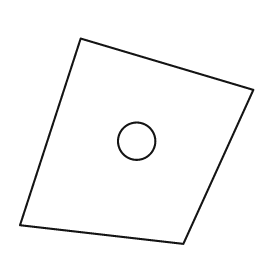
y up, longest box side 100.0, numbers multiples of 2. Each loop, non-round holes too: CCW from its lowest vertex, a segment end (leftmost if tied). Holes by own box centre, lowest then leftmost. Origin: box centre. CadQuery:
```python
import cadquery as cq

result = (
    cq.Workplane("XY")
    .moveTo(20.0, -44.0)
    .lineTo(50.0, 22.0)
    .lineTo(-24.0, 44.0)
    .lineTo(-50.0, -36.0)
    .close()
    .moveTo(0.0, 0.0)
    .circle(8.0)
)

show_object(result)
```